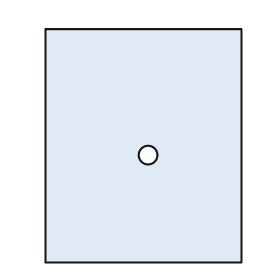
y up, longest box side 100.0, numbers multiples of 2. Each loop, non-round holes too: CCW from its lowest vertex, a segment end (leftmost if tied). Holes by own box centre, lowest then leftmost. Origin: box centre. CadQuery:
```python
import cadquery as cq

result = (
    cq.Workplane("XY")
    .moveTo(-42.0, -50.0)
    .lineTo(42.0, -50.0)
    .lineTo(42.0, 50.0)
    .lineTo(-42.0, 50.0)
    .close()
    .moveTo(2.0, -4.0)
    .circle(4.0)
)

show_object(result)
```